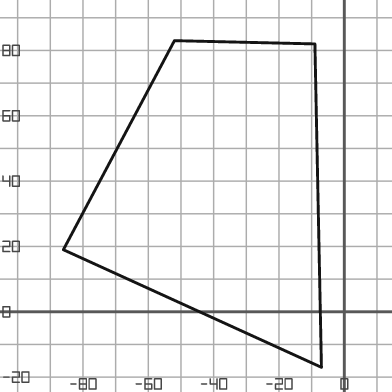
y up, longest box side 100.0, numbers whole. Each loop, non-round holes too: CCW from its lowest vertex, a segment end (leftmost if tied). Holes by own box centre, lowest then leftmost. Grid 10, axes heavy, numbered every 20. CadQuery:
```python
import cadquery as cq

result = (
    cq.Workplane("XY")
    .moveTo(-7.0, -17.0)
    .lineTo(-9.0, 82.0)
    .lineTo(-52.0, 83.0)
    .lineTo(-86.0, 19.0)
    .close()
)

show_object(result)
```